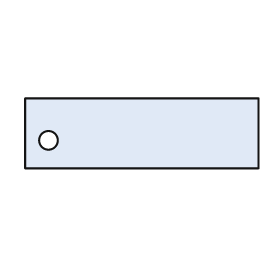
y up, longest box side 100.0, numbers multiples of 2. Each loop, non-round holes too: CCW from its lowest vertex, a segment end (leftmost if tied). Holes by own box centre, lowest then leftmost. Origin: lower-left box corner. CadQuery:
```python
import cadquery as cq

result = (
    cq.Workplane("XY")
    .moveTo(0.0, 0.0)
    .lineTo(100.0, 0.0)
    .lineTo(100.0, 30.0)
    .lineTo(0.0, 30.0)
    .close()
    .moveTo(10.0, 12.0)
    .circle(4.0)
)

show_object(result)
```